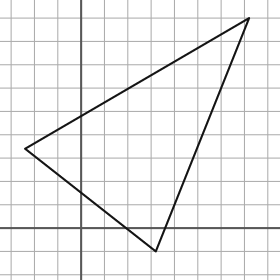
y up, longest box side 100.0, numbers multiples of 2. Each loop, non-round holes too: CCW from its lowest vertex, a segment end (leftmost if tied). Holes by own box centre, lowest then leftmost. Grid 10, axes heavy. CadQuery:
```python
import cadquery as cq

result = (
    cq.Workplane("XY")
    .moveTo(32.0, -10.0)
    .lineTo(72.0, 90.0)
    .lineTo(-24.0, 34.0)
    .close()
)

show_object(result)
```